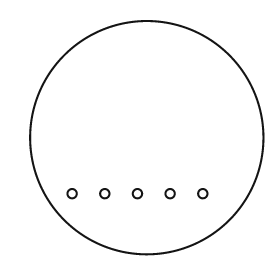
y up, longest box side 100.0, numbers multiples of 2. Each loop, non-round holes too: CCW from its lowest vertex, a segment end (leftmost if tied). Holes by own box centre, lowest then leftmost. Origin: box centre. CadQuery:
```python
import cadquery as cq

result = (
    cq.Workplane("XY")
    .moveTo(0.0, 0.0)
    .circle(50.0)
    .moveTo(-32.0, -24.0)
    .circle(2.0)
    .moveTo(-18.0, -24.0)
    .circle(2.0)
    .moveTo(-4.0, -24.0)
    .circle(2.0)
    .moveTo(10.0, -24.0)
    .circle(2.0)
    .moveTo(24.0, -24.0)
    .circle(2.0)
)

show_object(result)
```